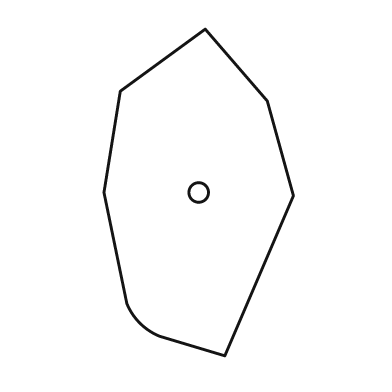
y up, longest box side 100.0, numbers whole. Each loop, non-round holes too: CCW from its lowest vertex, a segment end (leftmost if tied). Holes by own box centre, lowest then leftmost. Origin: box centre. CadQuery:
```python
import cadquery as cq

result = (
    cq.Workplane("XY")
    .moveTo(8.0, -50.0)
    .lineTo(29.0, -1.0)
    .lineTo(21.0, 28.0)
    .lineTo(2.0, 50.0)
    .lineTo(-24.0, 31.0)
    .lineTo(-29.0, 0.0)
    .lineTo(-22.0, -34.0)
    .threePointArc((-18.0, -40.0), (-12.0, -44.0))
    .close()
    .moveTo(0.0, 0.0)
    .circle(3.0)
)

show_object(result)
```